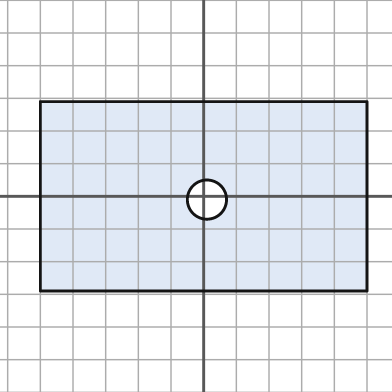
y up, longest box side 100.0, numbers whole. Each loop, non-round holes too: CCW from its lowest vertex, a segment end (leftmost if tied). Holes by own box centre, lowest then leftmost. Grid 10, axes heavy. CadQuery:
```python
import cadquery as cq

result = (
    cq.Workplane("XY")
    .moveTo(-50.0, -29.0)
    .lineTo(50.0, -29.0)
    .lineTo(50.0, 29.0)
    .lineTo(-50.0, 29.0)
    .close()
    .moveTo(1.0, -1.0)
    .circle(6.0)
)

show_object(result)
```